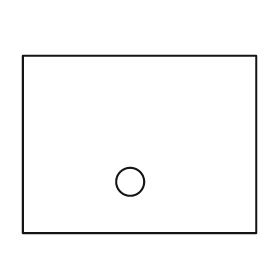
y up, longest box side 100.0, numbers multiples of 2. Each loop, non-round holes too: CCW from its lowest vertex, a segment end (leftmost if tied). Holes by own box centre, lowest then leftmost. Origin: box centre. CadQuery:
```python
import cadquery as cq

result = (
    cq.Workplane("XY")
    .moveTo(-50.0, -38.0)
    .lineTo(50.0, -38.0)
    .lineTo(50.0, 38.0)
    .lineTo(-50.0, 38.0)
    .close()
    .moveTo(-4.0, -16.0)
    .circle(6.0)
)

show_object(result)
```